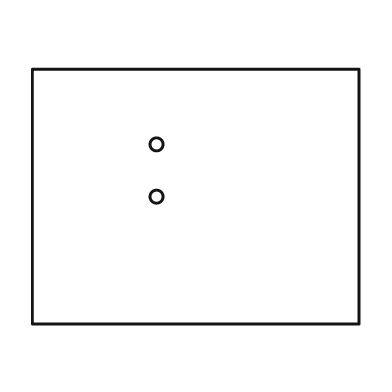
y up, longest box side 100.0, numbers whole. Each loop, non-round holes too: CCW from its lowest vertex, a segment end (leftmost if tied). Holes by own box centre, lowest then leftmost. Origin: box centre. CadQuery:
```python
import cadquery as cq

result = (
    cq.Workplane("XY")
    .moveTo(-50.0, -39.0)
    .lineTo(50.0, -39.0)
    .lineTo(50.0, 39.0)
    .lineTo(-50.0, 39.0)
    .close()
    .moveTo(-12.0, 0.0)
    .circle(2.0)
    .moveTo(-12.0, 16.0)
    .circle(2.0)
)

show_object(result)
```